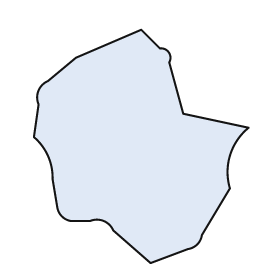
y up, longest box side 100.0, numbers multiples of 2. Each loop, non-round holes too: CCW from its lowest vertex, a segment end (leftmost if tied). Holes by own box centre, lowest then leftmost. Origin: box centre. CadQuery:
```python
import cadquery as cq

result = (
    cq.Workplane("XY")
    .moveTo(4.0, -50.0)
    .lineTo(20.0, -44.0)
    .threePointArc((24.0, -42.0), (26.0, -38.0))
    .lineTo(38.0, -18.0)
    .threePointArc((38.0, -4.0), (46.0, 8.0))
    .lineTo(18.0, 14.0)
    .lineTo(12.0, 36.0)
    .threePointArc((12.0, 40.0), (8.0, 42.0))
    .lineTo(0.0, 50.0)
    .lineTo(-28.0, 38.0)
    .lineTo(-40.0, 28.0)
    .threePointArc((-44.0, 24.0), (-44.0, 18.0))
    .lineTo(-46.0, 4.0)
    .threePointArc((-40.0, -4.0), (-38.0, -14.0))
    .lineTo(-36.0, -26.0)
    .threePointArc((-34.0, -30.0), (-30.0, -32.0))
    .lineTo(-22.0, -32.0)
    .threePointArc((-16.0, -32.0), (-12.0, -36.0))
    .close()
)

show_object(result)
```